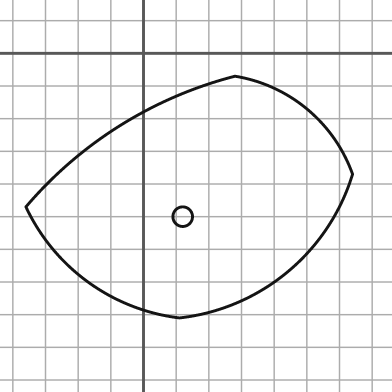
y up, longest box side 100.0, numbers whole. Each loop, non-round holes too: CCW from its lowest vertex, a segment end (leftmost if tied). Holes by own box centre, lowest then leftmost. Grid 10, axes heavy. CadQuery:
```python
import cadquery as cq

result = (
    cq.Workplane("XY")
    .moveTo(11.0, -81.0)
    .threePointArc((44.0, -67.0), (64.0, -37.0))
    .threePointArc((50.0, -17.0), (28.0, -7.0))
    .threePointArc((-7.0, -22.0), (-36.0, -47.0))
    .threePointArc((-17.0, -70.0), (11.0, -81.0))
    .close()
    .moveTo(12.0, -50.0)
    .circle(3.0)
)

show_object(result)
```